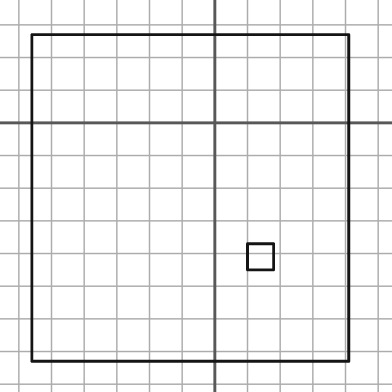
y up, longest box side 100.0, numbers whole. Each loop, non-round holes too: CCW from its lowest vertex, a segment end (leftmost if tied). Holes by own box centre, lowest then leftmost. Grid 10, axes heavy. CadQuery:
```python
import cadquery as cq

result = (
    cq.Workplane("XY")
    .moveTo(-56.0, -73.0)
    .lineTo(41.0, -73.0)
    .lineTo(41.0, 27.0)
    .lineTo(-56.0, 27.0)
    .close()
    .moveTo(10.0, -45.0)
    .lineTo(18.0, -45.0)
    .lineTo(18.0, -37.0)
    .lineTo(10.0, -37.0)
    .close()
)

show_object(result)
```